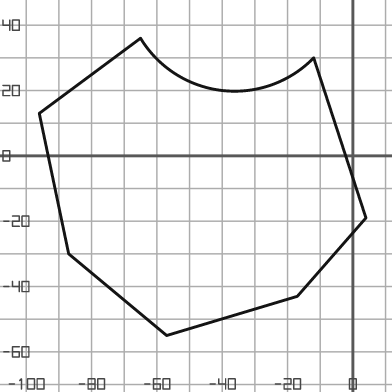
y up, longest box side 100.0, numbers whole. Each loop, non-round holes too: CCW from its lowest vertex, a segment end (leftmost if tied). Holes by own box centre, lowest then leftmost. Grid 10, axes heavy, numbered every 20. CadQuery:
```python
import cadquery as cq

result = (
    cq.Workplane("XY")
    .moveTo(-57.0, -55.0)
    .lineTo(-17.0, -43.0)
    .lineTo(4.0, -19.0)
    .lineTo(-12.0, 30.0)
    .threePointArc((-40.0, 20.0), (-65.0, 36.0))
    .lineTo(-96.0, 13.0)
    .lineTo(-87.0, -30.0)
    .close()
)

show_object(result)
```